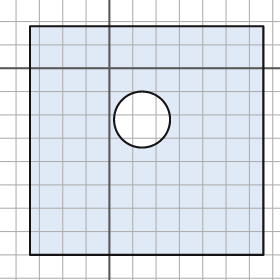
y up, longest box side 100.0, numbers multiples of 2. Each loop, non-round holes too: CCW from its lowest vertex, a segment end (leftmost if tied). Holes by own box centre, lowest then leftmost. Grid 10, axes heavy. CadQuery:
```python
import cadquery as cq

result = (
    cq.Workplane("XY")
    .moveTo(-34.0, -80.0)
    .lineTo(66.0, -80.0)
    .lineTo(66.0, 18.0)
    .lineTo(-34.0, 18.0)
    .close()
    .moveTo(14.0, -22.0)
    .circle(12.0)
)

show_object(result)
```